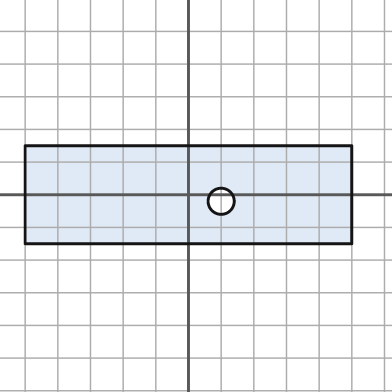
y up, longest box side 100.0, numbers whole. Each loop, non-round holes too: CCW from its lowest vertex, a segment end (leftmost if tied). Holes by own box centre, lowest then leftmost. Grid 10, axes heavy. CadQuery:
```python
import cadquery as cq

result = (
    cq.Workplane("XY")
    .moveTo(-50.0, -15.0)
    .lineTo(50.0, -15.0)
    .lineTo(50.0, 15.0)
    .lineTo(-50.0, 15.0)
    .close()
    .moveTo(10.0, -2.0)
    .circle(4.0)
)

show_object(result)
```